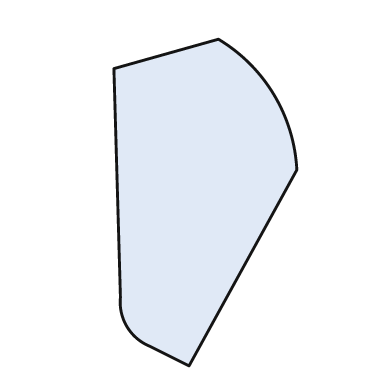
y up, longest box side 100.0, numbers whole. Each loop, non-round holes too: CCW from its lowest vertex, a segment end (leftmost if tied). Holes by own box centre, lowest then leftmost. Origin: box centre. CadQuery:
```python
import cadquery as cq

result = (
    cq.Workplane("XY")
    .moveTo(-5.0, -50.0)
    .lineTo(28.0, 10.0)
    .threePointArc((21.0, 33.0), (4.0, 50.0))
    .lineTo(-28.0, 41.0)
    .lineTo(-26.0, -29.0)
    .threePointArc((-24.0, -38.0), (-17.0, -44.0))
    .close()
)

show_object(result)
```